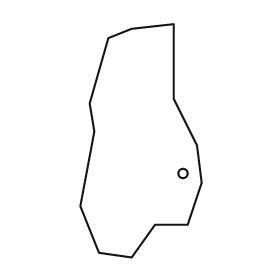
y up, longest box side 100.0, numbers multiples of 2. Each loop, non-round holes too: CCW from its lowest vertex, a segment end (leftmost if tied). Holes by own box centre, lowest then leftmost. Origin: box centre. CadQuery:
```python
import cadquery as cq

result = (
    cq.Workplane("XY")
    .moveTo(-4.0, -50.0)
    .lineTo(6.0, -36.0)
    .lineTo(20.0, -36.0)
    .lineTo(26.0, -18.0)
    .lineTo(24.0, -2.0)
    .lineTo(14.0, 18.0)
    .lineTo(14.0, 50.0)
    .lineTo(-4.0, 48.0)
    .lineTo(-14.0, 44.0)
    .lineTo(-22.0, 16.0)
    .lineTo(-20.0, 4.0)
    .lineTo(-26.0, -28.0)
    .lineTo(-18.0, -48.0)
    .close()
    .moveTo(18.0, -14.0)
    .circle(2.0)
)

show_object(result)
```